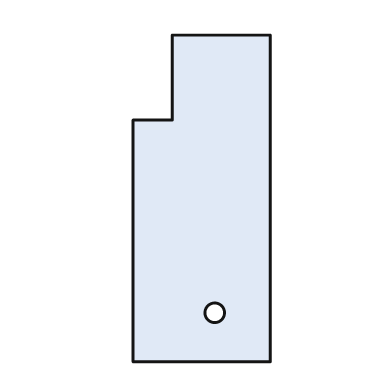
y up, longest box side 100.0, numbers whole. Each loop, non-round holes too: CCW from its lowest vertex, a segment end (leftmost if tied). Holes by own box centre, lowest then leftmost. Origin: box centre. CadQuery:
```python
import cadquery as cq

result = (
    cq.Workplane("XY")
    .moveTo(-21.0, -50.0)
    .lineTo(21.0, -50.0)
    .lineTo(21.0, 50.0)
    .lineTo(-9.0, 50.0)
    .lineTo(-9.0, 24.0)
    .lineTo(-21.0, 24.0)
    .close()
    .moveTo(4.0, -35.0)
    .circle(3.0)
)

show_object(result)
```